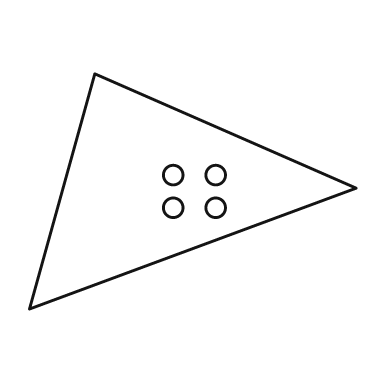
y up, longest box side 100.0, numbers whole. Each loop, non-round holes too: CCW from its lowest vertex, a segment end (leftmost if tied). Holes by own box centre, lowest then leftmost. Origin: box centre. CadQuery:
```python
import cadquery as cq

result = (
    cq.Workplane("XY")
    .moveTo(-50.0, -36.0)
    .lineTo(50.0, 1.0)
    .lineTo(-30.0, 36.0)
    .close()
    .moveTo(-6.0, -5.0)
    .circle(3.0)
    .moveTo(7.0, -5.0)
    .circle(3.0)
    .moveTo(-6.0, 5.0)
    .circle(3.0)
    .moveTo(7.0, 5.0)
    .circle(3.0)
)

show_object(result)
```